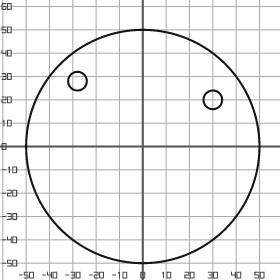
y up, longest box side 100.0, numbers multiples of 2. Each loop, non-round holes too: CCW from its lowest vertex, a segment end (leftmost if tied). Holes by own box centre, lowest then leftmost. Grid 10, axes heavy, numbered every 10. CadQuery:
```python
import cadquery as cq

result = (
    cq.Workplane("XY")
    .moveTo(0.0, 0.0)
    .circle(50.0)
    .moveTo(30.0, 20.0)
    .circle(4.0)
    .moveTo(-28.0, 28.0)
    .circle(4.0)
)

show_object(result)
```